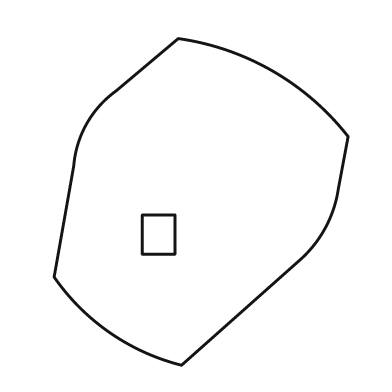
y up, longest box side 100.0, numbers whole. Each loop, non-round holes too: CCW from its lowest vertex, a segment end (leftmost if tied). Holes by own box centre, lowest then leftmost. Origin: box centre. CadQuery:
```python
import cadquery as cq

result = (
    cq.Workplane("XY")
    .moveTo(-6.0, -50.0)
    .lineTo(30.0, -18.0)
    .threePointArc((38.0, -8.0), (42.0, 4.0))
    .lineTo(45.0, 20.0)
    .threePointArc((22.0, 40.0), (-7.0, 50.0))
    .lineTo(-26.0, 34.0)
    .threePointArc((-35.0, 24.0), (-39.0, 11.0))
    .lineTo(-45.0, -23.0)
    .threePointArc((-28.0, -40.0), (-6.0, -50.0))
    .close()
    .moveTo(-18.0, -16.0)
    .lineTo(-8.0, -16.0)
    .lineTo(-8.0, -4.0)
    .lineTo(-18.0, -4.0)
    .close()
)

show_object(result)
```